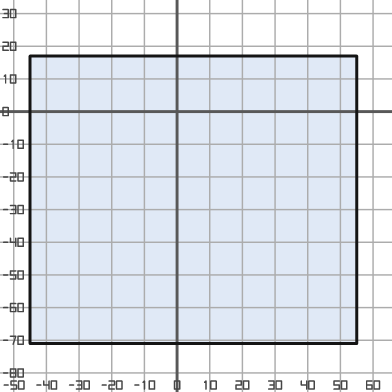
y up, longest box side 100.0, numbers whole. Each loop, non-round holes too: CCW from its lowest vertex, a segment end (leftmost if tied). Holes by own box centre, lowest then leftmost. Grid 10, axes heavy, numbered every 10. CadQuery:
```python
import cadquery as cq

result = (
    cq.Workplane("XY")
    .moveTo(-45.0, -71.0)
    .lineTo(55.0, -71.0)
    .lineTo(55.0, 17.0)
    .lineTo(-45.0, 17.0)
    .close()
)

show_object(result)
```